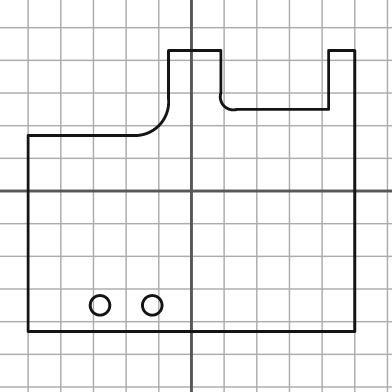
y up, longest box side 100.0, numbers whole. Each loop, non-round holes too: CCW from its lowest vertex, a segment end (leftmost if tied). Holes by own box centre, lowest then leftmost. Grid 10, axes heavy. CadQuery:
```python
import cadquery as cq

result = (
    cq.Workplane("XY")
    .moveTo(-50.0, -43.0)
    .lineTo(50.0, -43.0)
    .lineTo(50.0, 43.0)
    .lineTo(42.0, 43.0)
    .lineTo(42.0, 25.0)
    .lineTo(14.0, 25.0)
    .threePointArc((10.0, 26.0), (9.0, 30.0))
    .lineTo(9.0, 43.0)
    .lineTo(-7.0, 43.0)
    .lineTo(-7.0, 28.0)
    .threePointArc((-10.0, 20.0), (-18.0, 17.0))
    .lineTo(-50.0, 17.0)
    .close()
    .moveTo(-28.0, -35.0)
    .circle(3.0)
    .moveTo(-12.0, -35.0)
    .circle(3.0)
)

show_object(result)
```